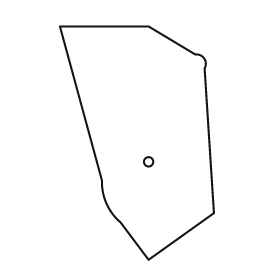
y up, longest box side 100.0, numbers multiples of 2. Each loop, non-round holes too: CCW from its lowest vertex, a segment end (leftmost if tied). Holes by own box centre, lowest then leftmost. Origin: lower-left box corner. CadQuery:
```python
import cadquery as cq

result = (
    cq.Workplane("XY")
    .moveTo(38.0, 0.0)
    .lineTo(66.0, 20.0)
    .lineTo(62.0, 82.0)
    .threePointArc((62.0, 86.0), (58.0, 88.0))
    .lineTo(38.0, 100.0)
    .lineTo(0.0, 100.0)
    .lineTo(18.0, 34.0)
    .threePointArc((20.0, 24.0), (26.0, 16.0))
    .close()
    .moveTo(38.0, 42.0)
    .circle(2.0)
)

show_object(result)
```